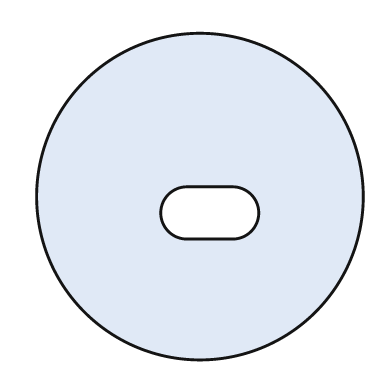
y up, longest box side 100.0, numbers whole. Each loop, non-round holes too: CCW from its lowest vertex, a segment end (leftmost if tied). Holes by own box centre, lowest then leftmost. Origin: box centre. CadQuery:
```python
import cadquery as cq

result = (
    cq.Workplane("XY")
    .moveTo(0.0, 0.0)
    .circle(50.0)
    .moveTo(-4.0, -13.0)
    .lineTo(10.0, -13.0)
    .threePointArc((18.0, -5.0), (10.0, 3.0))
    .lineTo(-4.0, 3.0)
    .threePointArc((-12.0, -5.0), (-4.0, -13.0))
    .close()
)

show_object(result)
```